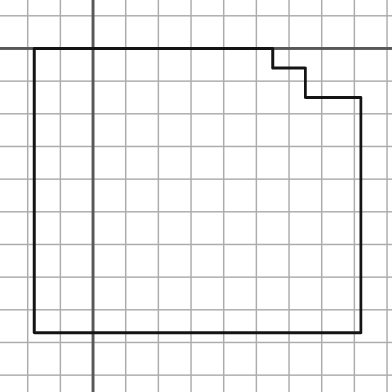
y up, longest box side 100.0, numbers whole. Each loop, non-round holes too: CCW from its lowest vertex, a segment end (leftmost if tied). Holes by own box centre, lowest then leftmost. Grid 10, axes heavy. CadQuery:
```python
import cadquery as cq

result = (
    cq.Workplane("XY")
    .moveTo(-18.0, -87.0)
    .lineTo(82.0, -87.0)
    .lineTo(82.0, -15.0)
    .lineTo(65.0, -15.0)
    .lineTo(65.0, -6.0)
    .lineTo(55.0, -6.0)
    .lineTo(55.0, 0.0)
    .lineTo(-18.0, 0.0)
    .close()
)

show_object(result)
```